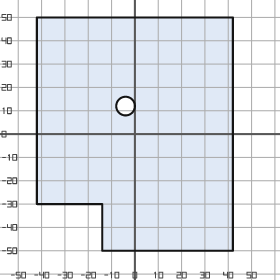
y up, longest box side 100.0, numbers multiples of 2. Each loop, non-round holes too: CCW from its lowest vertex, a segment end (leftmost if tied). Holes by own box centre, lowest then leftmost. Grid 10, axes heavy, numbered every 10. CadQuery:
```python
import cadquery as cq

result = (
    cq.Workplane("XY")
    .moveTo(-14.0, -50.0)
    .lineTo(42.0, -50.0)
    .lineTo(42.0, 50.0)
    .lineTo(-42.0, 50.0)
    .lineTo(-42.0, -30.0)
    .lineTo(-14.0, -30.0)
    .close()
    .moveTo(-4.0, 12.0)
    .circle(4.0)
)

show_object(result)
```